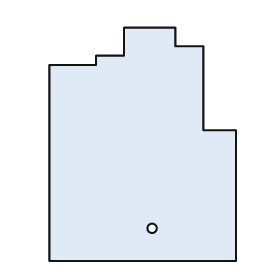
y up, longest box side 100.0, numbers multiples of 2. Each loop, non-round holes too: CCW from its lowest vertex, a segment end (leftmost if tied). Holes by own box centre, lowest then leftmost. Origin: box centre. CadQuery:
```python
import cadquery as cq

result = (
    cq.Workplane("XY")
    .moveTo(-40.0, -50.0)
    .lineTo(40.0, -50.0)
    .lineTo(40.0, 6.0)
    .lineTo(26.0, 6.0)
    .lineTo(26.0, 42.0)
    .lineTo(14.0, 42.0)
    .lineTo(14.0, 50.0)
    .lineTo(-8.0, 50.0)
    .lineTo(-8.0, 38.0)
    .lineTo(-20.0, 38.0)
    .lineTo(-20.0, 34.0)
    .lineTo(-40.0, 34.0)
    .close()
    .moveTo(4.0, -36.0)
    .circle(2.0)
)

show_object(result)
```